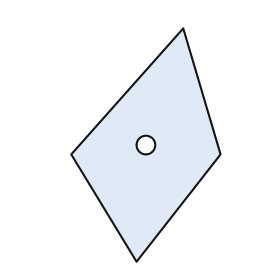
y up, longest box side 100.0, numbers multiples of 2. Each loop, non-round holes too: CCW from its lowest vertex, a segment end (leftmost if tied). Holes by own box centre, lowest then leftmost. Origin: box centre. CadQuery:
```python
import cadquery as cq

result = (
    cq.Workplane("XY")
    .moveTo(-4.0, -50.0)
    .lineTo(32.0, -4.0)
    .lineTo(16.0, 50.0)
    .lineTo(-32.0, -4.0)
    .close()
    .moveTo(0.0, 0.0)
    .circle(4.0)
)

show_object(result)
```